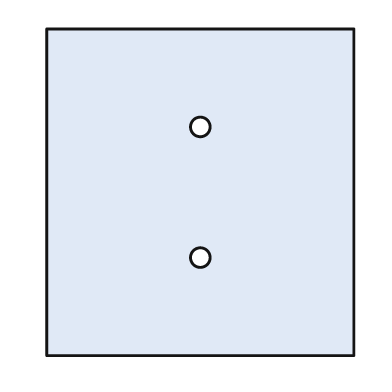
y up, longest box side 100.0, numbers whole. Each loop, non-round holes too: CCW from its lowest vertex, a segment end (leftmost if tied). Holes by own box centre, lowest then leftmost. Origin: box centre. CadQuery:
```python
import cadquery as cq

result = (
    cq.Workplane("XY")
    .moveTo(-47.0, -50.0)
    .lineTo(47.0, -50.0)
    .lineTo(47.0, 50.0)
    .lineTo(-47.0, 50.0)
    .close()
    .moveTo(0.0, -20.0)
    .circle(3.0)
    .moveTo(0.0, 20.0)
    .circle(3.0)
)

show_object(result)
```